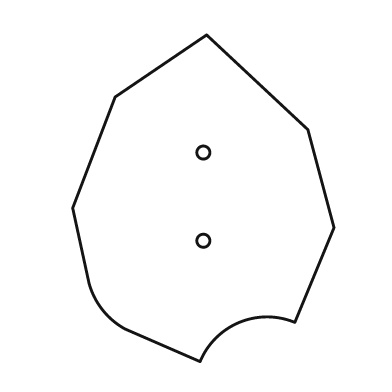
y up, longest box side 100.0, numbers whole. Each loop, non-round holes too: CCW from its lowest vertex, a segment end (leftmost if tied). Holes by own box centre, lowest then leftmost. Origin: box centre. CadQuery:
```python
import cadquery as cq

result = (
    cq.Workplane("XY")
    .moveTo(-1.0, -50.0)
    .threePointArc((11.0, -38.0), (28.0, -38.0))
    .lineTo(40.0, -9.0)
    .lineTo(32.0, 21.0)
    .lineTo(1.0, 50.0)
    .lineTo(-27.0, 31.0)
    .lineTo(-40.0, -3.0)
    .lineTo(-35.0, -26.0)
    .threePointArc((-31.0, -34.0), (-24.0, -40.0))
    .close()
    .moveTo(0.0, -13.0)
    .circle(2.0)
    .moveTo(0.0, 14.0)
    .circle(2.0)
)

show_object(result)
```